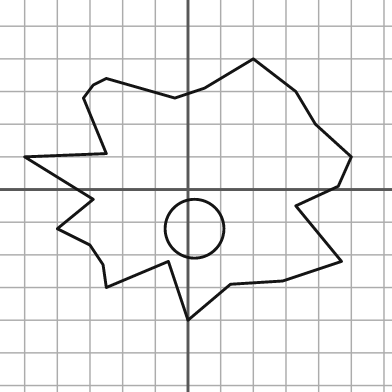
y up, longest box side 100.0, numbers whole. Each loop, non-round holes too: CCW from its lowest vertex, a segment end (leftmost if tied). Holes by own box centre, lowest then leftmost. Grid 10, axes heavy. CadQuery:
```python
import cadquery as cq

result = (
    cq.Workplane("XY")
    .moveTo(0.0, -40.0)
    .lineTo(13.0, -29.0)
    .lineTo(29.0, -28.0)
    .lineTo(47.0, -22.0)
    .lineTo(33.0, -5.0)
    .lineTo(46.0, 1.0)
    .lineTo(50.0, 10.0)
    .lineTo(39.0, 20.0)
    .lineTo(33.0, 30.0)
    .lineTo(20.0, 40.0)
    .lineTo(5.0, 31.0)
    .lineTo(-4.0, 28.0)
    .lineTo(-25.0, 34.0)
    .lineTo(-29.0, 32.0)
    .lineTo(-32.0, 28.0)
    .lineTo(-25.0, 11.0)
    .lineTo(-50.0, 10.0)
    .lineTo(-29.0, -3.0)
    .lineTo(-40.0, -12.0)
    .lineTo(-30.0, -17.0)
    .lineTo(-26.0, -23.0)
    .lineTo(-25.0, -30.0)
    .lineTo(-6.0, -22.0)
    .close()
    .moveTo(2.0, -12.0)
    .circle(9.0)
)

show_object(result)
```